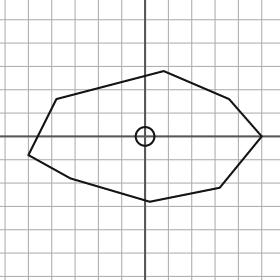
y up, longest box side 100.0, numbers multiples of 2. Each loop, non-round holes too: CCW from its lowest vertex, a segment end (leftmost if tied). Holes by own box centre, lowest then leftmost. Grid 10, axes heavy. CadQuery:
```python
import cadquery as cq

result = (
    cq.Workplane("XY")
    .moveTo(2.0, -28.0)
    .lineTo(32.0, -22.0)
    .lineTo(50.0, 0.0)
    .lineTo(36.0, 16.0)
    .lineTo(8.0, 28.0)
    .lineTo(-38.0, 16.0)
    .lineTo(-50.0, -8.0)
    .lineTo(-32.0, -18.0)
    .close()
    .moveTo(0.0, 0.0)
    .circle(4.0)
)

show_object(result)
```